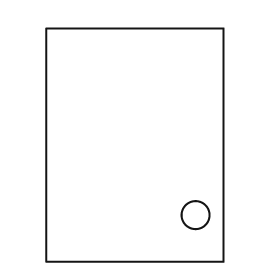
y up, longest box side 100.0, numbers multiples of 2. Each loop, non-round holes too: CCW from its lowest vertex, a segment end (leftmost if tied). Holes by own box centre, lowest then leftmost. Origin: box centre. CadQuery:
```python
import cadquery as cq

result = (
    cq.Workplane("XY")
    .moveTo(-38.0, -50.0)
    .lineTo(38.0, -50.0)
    .lineTo(38.0, 50.0)
    .lineTo(-38.0, 50.0)
    .close()
    .moveTo(26.0, -30.0)
    .circle(6.0)
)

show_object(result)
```